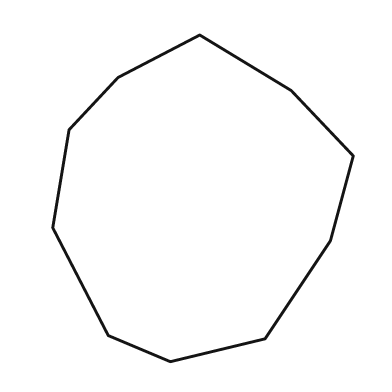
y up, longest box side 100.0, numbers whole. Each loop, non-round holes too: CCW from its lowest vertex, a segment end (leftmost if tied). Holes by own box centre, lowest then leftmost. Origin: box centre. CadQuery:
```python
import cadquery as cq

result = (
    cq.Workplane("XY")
    .moveTo(-10.0, -50.0)
    .lineTo(19.0, -43.0)
    .lineTo(39.0, -13.0)
    .lineTo(46.0, 13.0)
    .lineTo(27.0, 33.0)
    .lineTo(-1.0, 50.0)
    .lineTo(-26.0, 37.0)
    .lineTo(-41.0, 21.0)
    .lineTo(-46.0, -9.0)
    .lineTo(-29.0, -42.0)
    .close()
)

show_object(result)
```